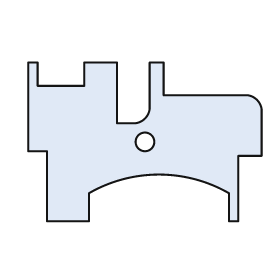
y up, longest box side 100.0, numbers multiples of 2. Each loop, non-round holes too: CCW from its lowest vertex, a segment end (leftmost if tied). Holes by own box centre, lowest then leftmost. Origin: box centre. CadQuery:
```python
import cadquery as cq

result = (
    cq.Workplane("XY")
    .moveTo(-42.0, -34.0)
    .lineTo(-24.0, -34.0)
    .lineTo(-24.0, -22.0)
    .threePointArc((6.0, -14.0), (36.0, -22.0))
    .lineTo(36.0, -34.0)
    .lineTo(40.0, -34.0)
    .lineTo(40.0, -6.0)
    .lineTo(50.0, -6.0)
    .lineTo(50.0, 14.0)
    .threePointArc((48.0, 18.0), (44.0, 20.0))
    .lineTo(8.0, 20.0)
    .lineTo(8.0, 34.0)
    .lineTo(2.0, 34.0)
    .lineTo(2.0, 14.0)
    .threePointArc((0.0, 10.0), (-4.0, 8.0))
    .lineTo(-12.0, 8.0)
    .lineTo(-12.0, 34.0)
    .lineTo(-26.0, 34.0)
    .lineTo(-26.0, 24.0)
    .lineTo(-46.0, 24.0)
    .lineTo(-46.0, 34.0)
    .lineTo(-50.0, 34.0)
    .lineTo(-50.0, -4.0)
    .lineTo(-42.0, -4.0)
    .close()
    .moveTo(0.0, 0.0)
    .circle(4.0)
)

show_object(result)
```